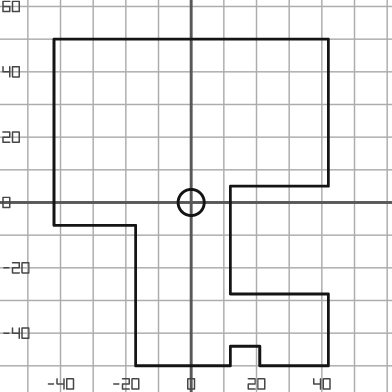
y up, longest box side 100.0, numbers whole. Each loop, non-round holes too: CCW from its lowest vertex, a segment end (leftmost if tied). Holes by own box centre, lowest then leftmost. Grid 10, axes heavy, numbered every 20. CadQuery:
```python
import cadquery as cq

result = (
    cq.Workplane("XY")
    .moveTo(-17.0, -50.0)
    .lineTo(12.0, -50.0)
    .lineTo(12.0, -44.0)
    .lineTo(21.0, -44.0)
    .lineTo(21.0, -50.0)
    .lineTo(42.0, -50.0)
    .lineTo(42.0, -28.0)
    .lineTo(12.0, -28.0)
    .lineTo(12.0, 5.0)
    .lineTo(42.0, 5.0)
    .lineTo(42.0, 50.0)
    .lineTo(-42.0, 50.0)
    .lineTo(-42.0, -7.0)
    .lineTo(-17.0, -7.0)
    .close()
    .moveTo(0.0, 0.0)
    .circle(4.0)
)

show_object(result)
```